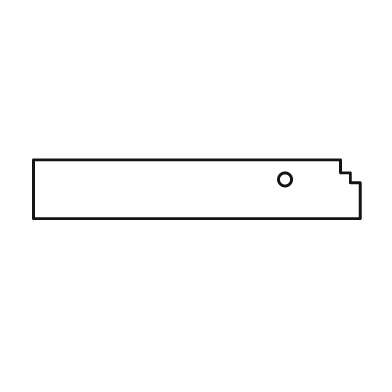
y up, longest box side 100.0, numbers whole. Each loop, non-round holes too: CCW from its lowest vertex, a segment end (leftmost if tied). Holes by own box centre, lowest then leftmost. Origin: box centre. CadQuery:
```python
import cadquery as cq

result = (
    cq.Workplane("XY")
    .moveTo(-50.0, -9.0)
    .lineTo(50.0, -9.0)
    .lineTo(50.0, 2.0)
    .lineTo(47.0, 2.0)
    .lineTo(47.0, 5.0)
    .lineTo(44.0, 5.0)
    .lineTo(44.0, 9.0)
    .lineTo(-50.0, 9.0)
    .close()
    .moveTo(27.0, 3.0)
    .circle(2.0)
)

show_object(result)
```